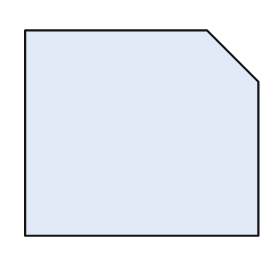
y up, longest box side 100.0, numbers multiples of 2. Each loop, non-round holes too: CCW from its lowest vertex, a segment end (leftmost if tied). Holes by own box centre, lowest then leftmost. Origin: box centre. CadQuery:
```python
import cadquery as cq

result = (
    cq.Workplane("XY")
    .moveTo(-50.0, -44.0)
    .lineTo(50.0, -44.0)
    .lineTo(50.0, 22.0)
    .lineTo(28.0, 44.0)
    .lineTo(-50.0, 44.0)
    .close()
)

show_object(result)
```